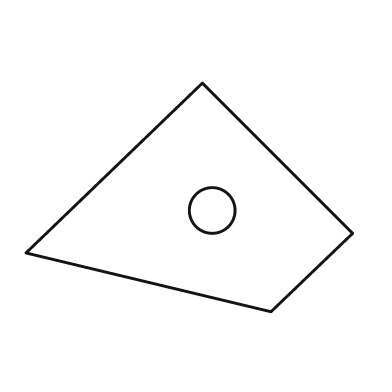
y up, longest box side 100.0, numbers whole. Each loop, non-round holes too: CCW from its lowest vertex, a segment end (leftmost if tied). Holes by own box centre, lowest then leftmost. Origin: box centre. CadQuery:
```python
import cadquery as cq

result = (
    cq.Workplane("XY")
    .moveTo(25.0, -35.0)
    .lineTo(50.0, -11.0)
    .lineTo(4.0, 35.0)
    .lineTo(-50.0, -17.0)
    .close()
    .moveTo(7.0, -4.0)
    .circle(7.0)
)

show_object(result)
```